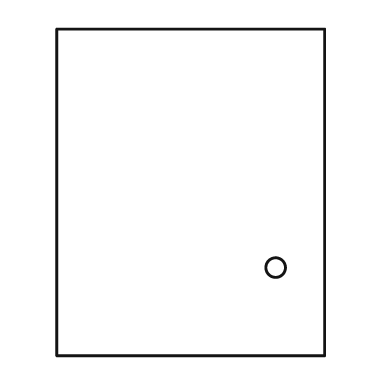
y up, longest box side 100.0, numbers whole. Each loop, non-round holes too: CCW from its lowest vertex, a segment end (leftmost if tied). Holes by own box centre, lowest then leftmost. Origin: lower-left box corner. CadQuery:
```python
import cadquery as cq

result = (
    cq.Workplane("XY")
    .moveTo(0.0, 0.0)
    .lineTo(82.0, 0.0)
    .lineTo(82.0, 100.0)
    .lineTo(0.0, 100.0)
    .close()
    .moveTo(67.0, 27.0)
    .circle(3.0)
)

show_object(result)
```